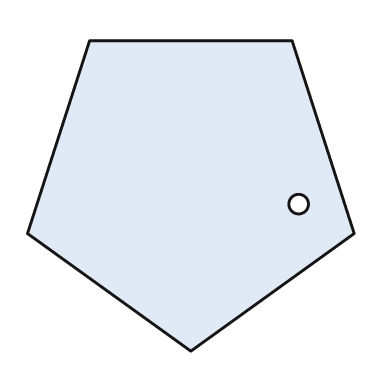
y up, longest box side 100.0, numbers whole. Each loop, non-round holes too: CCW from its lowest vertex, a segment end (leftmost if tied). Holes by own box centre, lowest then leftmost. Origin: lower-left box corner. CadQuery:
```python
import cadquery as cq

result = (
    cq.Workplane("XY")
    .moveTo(50.0, 0.0)
    .lineTo(100.0, 36.0)
    .lineTo(81.0, 95.0)
    .lineTo(19.0, 95.0)
    .lineTo(0.0, 36.0)
    .close()
    .moveTo(83.0, 45.0)
    .circle(3.0)
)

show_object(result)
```